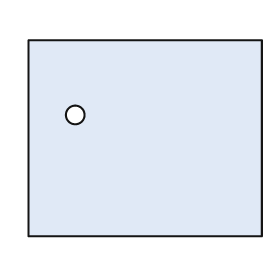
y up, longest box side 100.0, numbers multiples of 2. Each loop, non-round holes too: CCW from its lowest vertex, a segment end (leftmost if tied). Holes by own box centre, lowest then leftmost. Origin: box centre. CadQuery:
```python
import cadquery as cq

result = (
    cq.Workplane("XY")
    .moveTo(-50.0, -42.0)
    .lineTo(50.0, -42.0)
    .lineTo(50.0, 42.0)
    .lineTo(-50.0, 42.0)
    .close()
    .moveTo(-30.0, 10.0)
    .circle(4.0)
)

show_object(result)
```